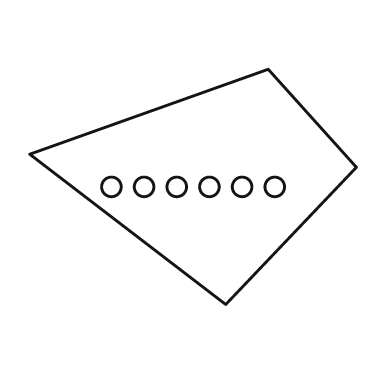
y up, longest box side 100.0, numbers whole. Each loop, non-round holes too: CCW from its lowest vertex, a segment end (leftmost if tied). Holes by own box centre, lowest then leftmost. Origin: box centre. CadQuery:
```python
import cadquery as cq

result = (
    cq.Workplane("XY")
    .moveTo(10.0, -36.0)
    .lineTo(50.0, 6.0)
    .lineTo(23.0, 36.0)
    .lineTo(-50.0, 10.0)
    .close()
    .moveTo(-25.0, 0.0)
    .circle(3.0)
    .moveTo(-15.0, 0.0)
    .circle(3.0)
    .moveTo(-5.0, 0.0)
    .circle(3.0)
    .moveTo(5.0, 0.0)
    .circle(3.0)
    .moveTo(15.0, 0.0)
    .circle(3.0)
    .moveTo(25.0, 0.0)
    .circle(3.0)
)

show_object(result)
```